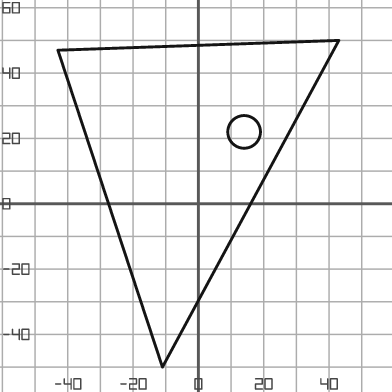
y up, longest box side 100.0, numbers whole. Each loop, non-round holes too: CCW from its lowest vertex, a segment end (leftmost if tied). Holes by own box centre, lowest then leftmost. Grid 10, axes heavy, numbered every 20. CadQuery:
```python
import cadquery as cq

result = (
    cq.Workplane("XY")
    .moveTo(-11.0, -50.0)
    .lineTo(43.0, 50.0)
    .lineTo(-43.0, 47.0)
    .close()
    .moveTo(14.0, 22.0)
    .circle(5.0)
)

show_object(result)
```